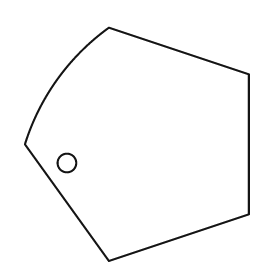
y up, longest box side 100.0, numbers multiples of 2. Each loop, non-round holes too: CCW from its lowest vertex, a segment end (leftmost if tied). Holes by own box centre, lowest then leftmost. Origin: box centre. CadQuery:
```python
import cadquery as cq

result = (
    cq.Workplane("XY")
    .moveTo(-12.0, -50.0)
    .lineTo(48.0, -30.0)
    .lineTo(48.0, 30.0)
    .lineTo(-12.0, 50.0)
    .threePointArc((-34.0, 28.0), (-48.0, 0.0))
    .close()
    .moveTo(-30.0, -8.0)
    .circle(4.0)
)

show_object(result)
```